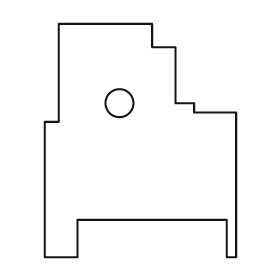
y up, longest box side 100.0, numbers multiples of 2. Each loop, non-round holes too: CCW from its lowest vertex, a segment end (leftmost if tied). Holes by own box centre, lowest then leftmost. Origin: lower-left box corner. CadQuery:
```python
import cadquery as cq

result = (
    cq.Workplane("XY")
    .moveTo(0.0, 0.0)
    .lineTo(14.0, 0.0)
    .lineTo(14.0, 16.0)
    .lineTo(78.0, 16.0)
    .lineTo(78.0, 0.0)
    .lineTo(82.0, 0.0)
    .lineTo(82.0, 62.0)
    .lineTo(64.0, 62.0)
    .lineTo(64.0, 66.0)
    .lineTo(56.0, 66.0)
    .lineTo(56.0, 90.0)
    .lineTo(46.0, 90.0)
    .lineTo(46.0, 100.0)
    .lineTo(6.0, 100.0)
    .lineTo(6.0, 58.0)
    .lineTo(0.0, 58.0)
    .close()
    .moveTo(32.0, 66.0)
    .circle(6.0)
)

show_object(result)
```